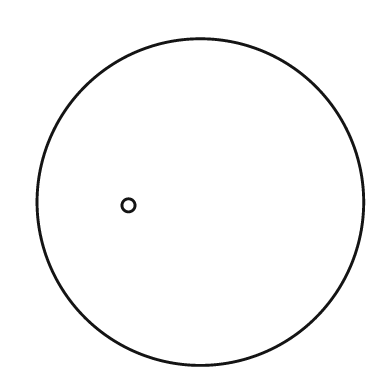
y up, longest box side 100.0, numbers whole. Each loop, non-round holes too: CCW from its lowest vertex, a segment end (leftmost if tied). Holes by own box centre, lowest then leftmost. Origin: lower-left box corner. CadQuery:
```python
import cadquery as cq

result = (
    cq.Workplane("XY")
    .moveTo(50.0, 50.0)
    .circle(50.0)
    .moveTo(28.0, 49.0)
    .circle(2.0)
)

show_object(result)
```